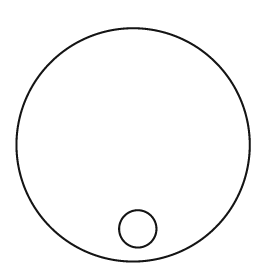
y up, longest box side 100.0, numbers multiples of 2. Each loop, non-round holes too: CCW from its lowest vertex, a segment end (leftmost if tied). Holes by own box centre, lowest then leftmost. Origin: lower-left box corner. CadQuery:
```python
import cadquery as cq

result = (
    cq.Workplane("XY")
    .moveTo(50.0, 50.0)
    .circle(50.0)
    .moveTo(52.0, 14.0)
    .circle(8.0)
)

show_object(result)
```